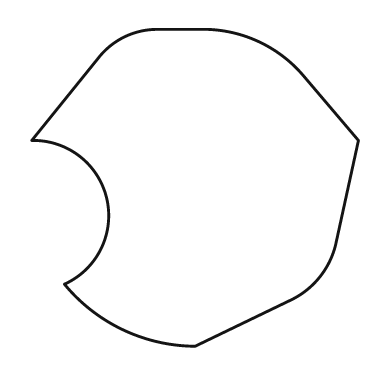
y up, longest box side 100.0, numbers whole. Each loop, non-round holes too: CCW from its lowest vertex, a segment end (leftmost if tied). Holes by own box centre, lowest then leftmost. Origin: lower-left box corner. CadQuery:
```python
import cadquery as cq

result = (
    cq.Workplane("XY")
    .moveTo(50.0, 0.0)
    .lineTo(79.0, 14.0)
    .threePointArc((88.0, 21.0), (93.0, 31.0))
    .lineTo(100.0, 63.0)
    .lineTo(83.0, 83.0)
    .threePointArc((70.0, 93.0), (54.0, 97.0))
    .lineTo(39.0, 97.0)
    .threePointArc((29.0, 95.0), (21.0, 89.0))
    .lineTo(0.0, 63.0)
    .threePointArc((23.0, 45.0), (10.0, 19.0))
    .threePointArc((28.0, 5.0), (50.0, 0.0))
    .close()
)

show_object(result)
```